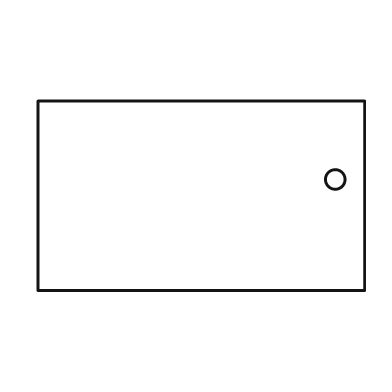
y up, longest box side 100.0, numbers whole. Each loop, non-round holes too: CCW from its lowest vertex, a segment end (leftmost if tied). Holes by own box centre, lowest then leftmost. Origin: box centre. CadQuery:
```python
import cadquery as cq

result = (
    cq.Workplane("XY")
    .moveTo(-50.0, -29.0)
    .lineTo(50.0, -29.0)
    .lineTo(50.0, 29.0)
    .lineTo(-50.0, 29.0)
    .close()
    .moveTo(41.0, 5.0)
    .circle(3.0)
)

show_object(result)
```